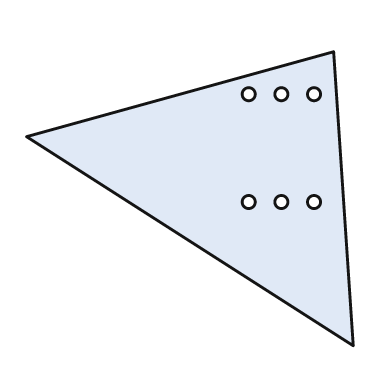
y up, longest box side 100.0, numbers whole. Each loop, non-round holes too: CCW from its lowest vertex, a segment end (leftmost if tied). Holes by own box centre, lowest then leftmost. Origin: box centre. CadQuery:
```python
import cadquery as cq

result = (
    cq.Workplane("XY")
    .moveTo(50.0, -45.0)
    .lineTo(44.0, 45.0)
    .lineTo(-50.0, 19.0)
    .close()
    .moveTo(18.0, -1.0)
    .circle(2.0)
    .moveTo(28.0, -1.0)
    .circle(2.0)
    .moveTo(38.0, -1.0)
    .circle(2.0)
    .moveTo(18.0, 32.0)
    .circle(2.0)
    .moveTo(28.0, 32.0)
    .circle(2.0)
    .moveTo(38.0, 32.0)
    .circle(2.0)
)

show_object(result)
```